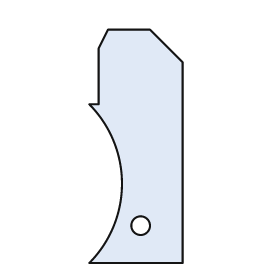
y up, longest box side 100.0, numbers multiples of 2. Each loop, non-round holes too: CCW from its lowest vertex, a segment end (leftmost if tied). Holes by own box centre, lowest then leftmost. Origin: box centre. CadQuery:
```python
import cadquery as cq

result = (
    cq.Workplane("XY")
    .moveTo(-20.0, -50.0)
    .lineTo(20.0, -50.0)
    .lineTo(20.0, 36.0)
    .lineTo(6.0, 50.0)
    .lineTo(-12.0, 50.0)
    .lineTo(-16.0, 42.0)
    .lineTo(-16.0, 18.0)
    .lineTo(-20.0, 18.0)
    .threePointArc((-6.0, -16.0), (-20.0, -50.0))
    .close()
    .moveTo(2.0, -34.0)
    .circle(4.0)
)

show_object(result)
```